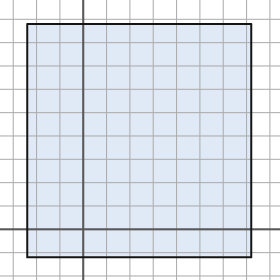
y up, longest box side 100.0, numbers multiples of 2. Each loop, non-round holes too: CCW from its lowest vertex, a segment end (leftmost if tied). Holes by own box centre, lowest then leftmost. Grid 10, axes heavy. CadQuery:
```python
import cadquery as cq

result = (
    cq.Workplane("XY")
    .moveTo(-24.0, -12.0)
    .lineTo(72.0, -12.0)
    .lineTo(72.0, 88.0)
    .lineTo(-24.0, 88.0)
    .close()
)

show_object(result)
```